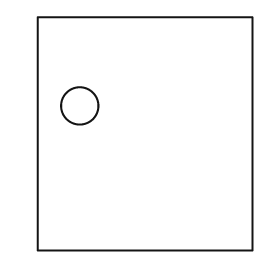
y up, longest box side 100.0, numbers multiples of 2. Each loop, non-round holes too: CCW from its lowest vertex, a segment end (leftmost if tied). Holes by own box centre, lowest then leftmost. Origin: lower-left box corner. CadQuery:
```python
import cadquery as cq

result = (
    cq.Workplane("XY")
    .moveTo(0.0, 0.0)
    .lineTo(92.0, 0.0)
    .lineTo(92.0, 100.0)
    .lineTo(0.0, 100.0)
    .close()
    .moveTo(18.0, 62.0)
    .circle(8.0)
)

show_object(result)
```